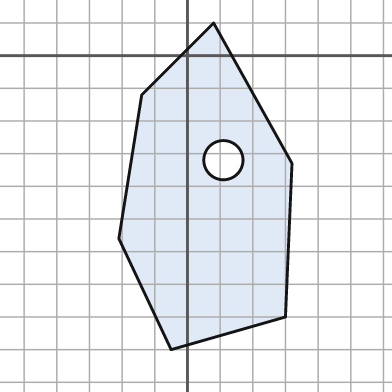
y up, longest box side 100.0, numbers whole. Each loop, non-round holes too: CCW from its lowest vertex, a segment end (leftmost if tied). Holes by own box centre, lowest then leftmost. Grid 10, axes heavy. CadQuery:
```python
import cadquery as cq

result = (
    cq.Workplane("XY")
    .moveTo(-5.0, -90.0)
    .lineTo(30.0, -80.0)
    .lineTo(32.0, -33.0)
    .lineTo(8.0, 10.0)
    .lineTo(-14.0, -12.0)
    .lineTo(-21.0, -56.0)
    .close()
    .moveTo(11.0, -32.0)
    .circle(6.0)
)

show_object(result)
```